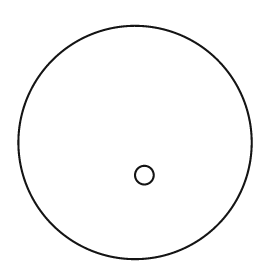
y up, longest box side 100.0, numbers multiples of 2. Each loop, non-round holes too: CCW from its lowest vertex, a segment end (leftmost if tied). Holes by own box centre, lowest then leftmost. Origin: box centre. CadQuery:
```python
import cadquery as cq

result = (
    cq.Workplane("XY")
    .moveTo(0.0, 0.0)
    .circle(50.0)
    .moveTo(4.0, -14.0)
    .circle(4.0)
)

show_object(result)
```